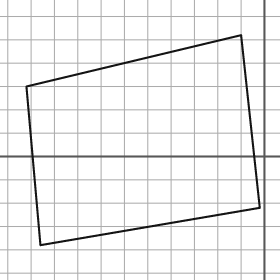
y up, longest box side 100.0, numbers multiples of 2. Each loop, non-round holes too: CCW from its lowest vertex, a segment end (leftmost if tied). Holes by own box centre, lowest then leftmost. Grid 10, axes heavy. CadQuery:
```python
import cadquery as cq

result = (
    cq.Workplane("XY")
    .moveTo(-96.0, -38.0)
    .lineTo(-2.0, -22.0)
    .lineTo(-10.0, 52.0)
    .lineTo(-102.0, 30.0)
    .close()
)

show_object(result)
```